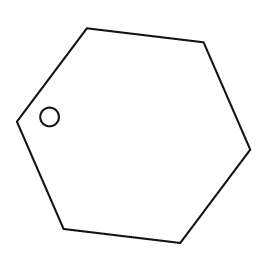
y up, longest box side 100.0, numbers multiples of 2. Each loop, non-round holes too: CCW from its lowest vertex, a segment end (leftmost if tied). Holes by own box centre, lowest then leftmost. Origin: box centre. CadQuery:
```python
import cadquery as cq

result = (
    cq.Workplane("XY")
    .moveTo(20.0, -46.0)
    .lineTo(50.0, -6.0)
    .lineTo(30.0, 40.0)
    .lineTo(-20.0, 46.0)
    .lineTo(-50.0, 6.0)
    .lineTo(-30.0, -40.0)
    .close()
    .moveTo(-36.0, 8.0)
    .circle(4.0)
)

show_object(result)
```